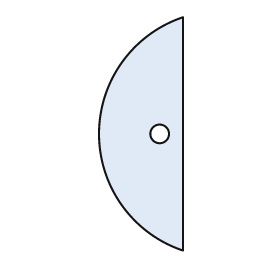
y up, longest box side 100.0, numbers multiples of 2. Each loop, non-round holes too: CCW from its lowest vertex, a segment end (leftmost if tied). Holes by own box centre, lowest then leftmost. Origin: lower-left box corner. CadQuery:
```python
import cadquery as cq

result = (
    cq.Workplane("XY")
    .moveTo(36.0, 0.0)
    .lineTo(36.0, 100.0)
    .threePointArc((0.0, 50.0), (36.0, 0.0))
    .close()
    .moveTo(26.0, 50.0)
    .circle(4.0)
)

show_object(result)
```